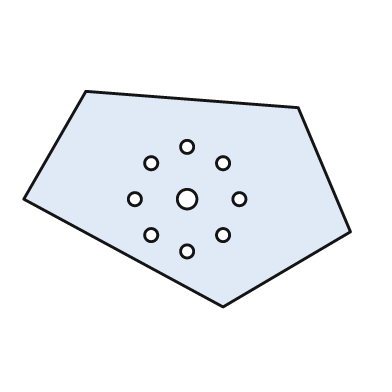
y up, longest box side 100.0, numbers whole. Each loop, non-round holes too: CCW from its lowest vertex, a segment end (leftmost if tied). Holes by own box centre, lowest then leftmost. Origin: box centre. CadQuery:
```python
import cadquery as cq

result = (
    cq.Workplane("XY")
    .moveTo(11.0, -33.0)
    .lineTo(50.0, -10.0)
    .lineTo(34.0, 28.0)
    .lineTo(-31.0, 33.0)
    .lineTo(-50.0, 0.0)
    .close()
    .moveTo(0.0, -16.0)
    .circle(2.0)
    .moveTo(-11.0, -11.0)
    .circle(2.0)
    .moveTo(11.0, -11.0)
    .circle(2.0)
    .moveTo(-16.0, 0.0)
    .circle(2.0)
    .moveTo(0.0, 0.0)
    .circle(3.0)
    .moveTo(16.0, 0.0)
    .circle(2.0)
    .moveTo(-11.0, 11.0)
    .circle(2.0)
    .moveTo(11.0, 11.0)
    .circle(2.0)
    .moveTo(0.0, 16.0)
    .circle(2.0)
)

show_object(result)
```